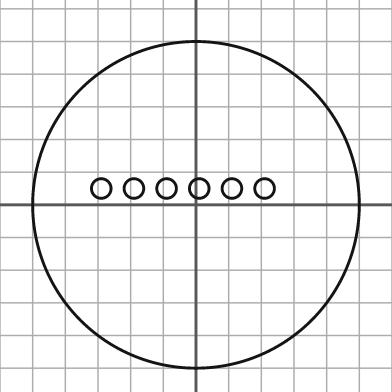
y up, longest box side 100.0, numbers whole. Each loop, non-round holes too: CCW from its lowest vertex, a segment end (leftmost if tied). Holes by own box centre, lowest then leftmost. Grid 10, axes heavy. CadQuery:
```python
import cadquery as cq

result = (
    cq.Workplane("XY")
    .moveTo(0.0, 0.0)
    .circle(50.0)
    .moveTo(-29.0, 5.0)
    .circle(3.0)
    .moveTo(-19.0, 5.0)
    .circle(3.0)
    .moveTo(-9.0, 5.0)
    .circle(3.0)
    .moveTo(1.0, 5.0)
    .circle(3.0)
    .moveTo(11.0, 5.0)
    .circle(3.0)
    .moveTo(21.0, 5.0)
    .circle(3.0)
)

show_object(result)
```